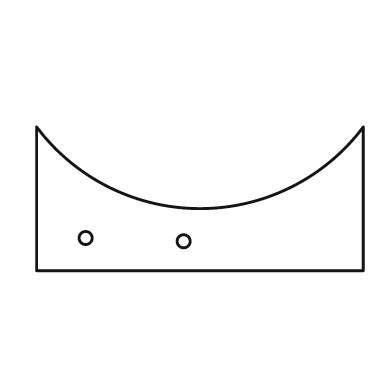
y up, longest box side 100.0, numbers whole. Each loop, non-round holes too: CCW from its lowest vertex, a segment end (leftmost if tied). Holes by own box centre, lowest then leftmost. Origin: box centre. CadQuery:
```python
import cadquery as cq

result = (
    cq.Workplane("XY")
    .moveTo(-50.0, -22.0)
    .lineTo(50.0, -22.0)
    .lineTo(50.0, 22.0)
    .threePointArc((0.0, -3.0), (-50.0, 22.0))
    .close()
    .moveTo(-5.0, -13.0)
    .circle(2.0)
    .moveTo(-35.0, -12.0)
    .circle(2.0)
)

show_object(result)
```